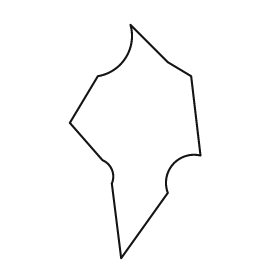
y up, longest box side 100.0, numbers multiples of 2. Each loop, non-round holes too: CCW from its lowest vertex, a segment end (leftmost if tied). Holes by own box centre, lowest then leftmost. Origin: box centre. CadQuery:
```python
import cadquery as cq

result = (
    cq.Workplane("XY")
    .moveTo(-6.0, -50.0)
    .lineTo(14.0, -22.0)
    .threePointArc((16.0, -10.0), (28.0, -6.0))
    .lineTo(24.0, 28.0)
    .lineTo(14.0, 34.0)
    .lineTo(-2.0, 50.0)
    .threePointArc((-4.0, 36.0), (-16.0, 28.0))
    .lineTo(-28.0, 8.0)
    .lineTo(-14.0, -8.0)
    .threePointArc((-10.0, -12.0), (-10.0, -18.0))
    .close()
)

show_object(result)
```